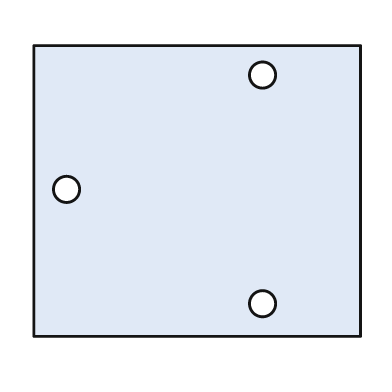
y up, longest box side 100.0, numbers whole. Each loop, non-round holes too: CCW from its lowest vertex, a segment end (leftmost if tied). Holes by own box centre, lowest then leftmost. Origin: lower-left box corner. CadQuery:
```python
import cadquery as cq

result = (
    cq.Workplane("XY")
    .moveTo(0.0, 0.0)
    .lineTo(100.0, 0.0)
    .lineTo(100.0, 89.0)
    .lineTo(0.0, 89.0)
    .close()
    .moveTo(70.0, 10.0)
    .circle(4.0)
    .moveTo(10.0, 45.0)
    .circle(4.0)
    .moveTo(70.0, 80.0)
    .circle(4.0)
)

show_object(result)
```